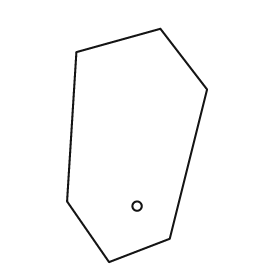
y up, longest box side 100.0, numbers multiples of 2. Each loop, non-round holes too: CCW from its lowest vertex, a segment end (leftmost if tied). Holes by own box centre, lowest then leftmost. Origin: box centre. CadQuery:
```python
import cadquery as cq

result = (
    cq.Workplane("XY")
    .moveTo(-12.0, -50.0)
    .lineTo(14.0, -40.0)
    .lineTo(30.0, 24.0)
    .lineTo(10.0, 50.0)
    .lineTo(-26.0, 40.0)
    .lineTo(-30.0, -24.0)
    .close()
    .moveTo(0.0, -26.0)
    .circle(2.0)
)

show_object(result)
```